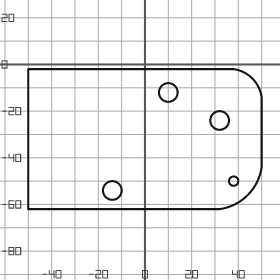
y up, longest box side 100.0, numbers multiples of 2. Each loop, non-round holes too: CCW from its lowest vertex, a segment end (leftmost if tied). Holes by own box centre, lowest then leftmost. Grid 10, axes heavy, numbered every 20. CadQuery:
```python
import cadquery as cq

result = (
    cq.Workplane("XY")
    .moveTo(-50.0, -62.0)
    .lineTo(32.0, -62.0)
    .threePointArc((44.0, -56.0), (50.0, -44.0))
    .lineTo(50.0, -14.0)
    .threePointArc((46.0, -6.0), (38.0, -2.0))
    .lineTo(-50.0, -2.0)
    .close()
    .moveTo(-14.0, -54.0)
    .circle(4.0)
    .moveTo(38.0, -50.0)
    .circle(2.0)
    .moveTo(32.0, -24.0)
    .circle(4.0)
    .moveTo(10.0, -12.0)
    .circle(4.0)
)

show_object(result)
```